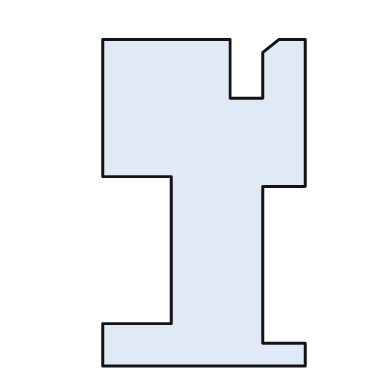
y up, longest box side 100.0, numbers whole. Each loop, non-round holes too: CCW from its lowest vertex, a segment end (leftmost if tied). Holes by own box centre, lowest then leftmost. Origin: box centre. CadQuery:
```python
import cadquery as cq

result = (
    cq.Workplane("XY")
    .moveTo(-31.0, -50.0)
    .lineTo(31.0, -50.0)
    .lineTo(31.0, -43.0)
    .lineTo(18.0, -43.0)
    .lineTo(18.0, 5.0)
    .lineTo(31.0, 5.0)
    .lineTo(31.0, 50.0)
    .lineTo(23.0, 50.0)
    .lineTo(18.0, 46.0)
    .lineTo(18.0, 32.0)
    .lineTo(8.0, 32.0)
    .lineTo(8.0, 50.0)
    .lineTo(-31.0, 50.0)
    .lineTo(-31.0, 8.0)
    .lineTo(-10.0, 8.0)
    .lineTo(-10.0, -37.0)
    .lineTo(-31.0, -37.0)
    .close()
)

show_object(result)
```